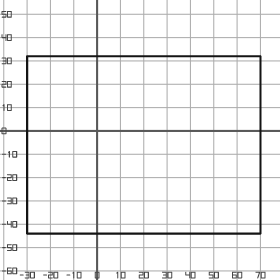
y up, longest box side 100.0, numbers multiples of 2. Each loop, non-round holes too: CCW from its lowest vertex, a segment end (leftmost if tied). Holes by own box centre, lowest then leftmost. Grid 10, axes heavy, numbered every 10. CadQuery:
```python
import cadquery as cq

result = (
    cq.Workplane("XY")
    .moveTo(-30.0, -44.0)
    .lineTo(70.0, -44.0)
    .lineTo(70.0, 32.0)
    .lineTo(-30.0, 32.0)
    .close()
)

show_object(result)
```